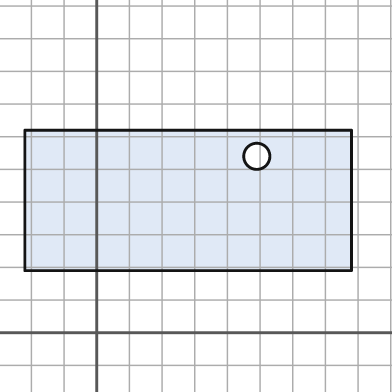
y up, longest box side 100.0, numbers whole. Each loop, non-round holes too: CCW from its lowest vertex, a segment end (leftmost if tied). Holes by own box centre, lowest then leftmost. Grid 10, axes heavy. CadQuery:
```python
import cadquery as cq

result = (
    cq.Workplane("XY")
    .moveTo(-22.0, 19.0)
    .lineTo(78.0, 19.0)
    .lineTo(78.0, 62.0)
    .lineTo(-22.0, 62.0)
    .close()
    .moveTo(49.0, 54.0)
    .circle(4.0)
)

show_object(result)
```